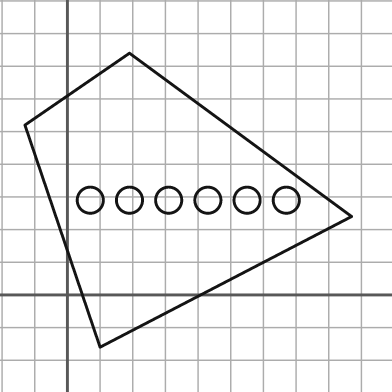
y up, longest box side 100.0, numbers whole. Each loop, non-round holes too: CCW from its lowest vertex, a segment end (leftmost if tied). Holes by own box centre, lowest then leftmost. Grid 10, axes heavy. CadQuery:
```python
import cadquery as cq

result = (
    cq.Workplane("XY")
    .moveTo(10.0, -16.0)
    .lineTo(87.0, 24.0)
    .lineTo(19.0, 74.0)
    .lineTo(-13.0, 52.0)
    .close()
    .moveTo(7.0, 29.0)
    .circle(4.0)
    .moveTo(19.0, 29.0)
    .circle(4.0)
    .moveTo(31.0, 29.0)
    .circle(4.0)
    .moveTo(43.0, 29.0)
    .circle(4.0)
    .moveTo(55.0, 29.0)
    .circle(4.0)
    .moveTo(67.0, 29.0)
    .circle(4.0)
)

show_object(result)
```